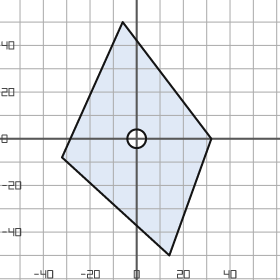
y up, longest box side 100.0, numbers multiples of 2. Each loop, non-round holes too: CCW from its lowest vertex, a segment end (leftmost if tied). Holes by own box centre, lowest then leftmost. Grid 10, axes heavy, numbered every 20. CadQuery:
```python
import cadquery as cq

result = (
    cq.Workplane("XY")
    .moveTo(14.0, -50.0)
    .lineTo(32.0, 0.0)
    .lineTo(-6.0, 50.0)
    .lineTo(-32.0, -8.0)
    .close()
    .moveTo(0.0, 0.0)
    .circle(4.0)
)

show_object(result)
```